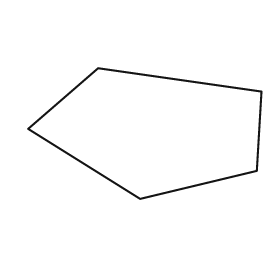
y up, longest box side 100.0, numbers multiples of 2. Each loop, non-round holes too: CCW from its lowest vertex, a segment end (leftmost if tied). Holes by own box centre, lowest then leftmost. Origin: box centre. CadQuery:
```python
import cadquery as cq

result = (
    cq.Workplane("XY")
    .moveTo(-2.0, -28.0)
    .lineTo(48.0, -16.0)
    .lineTo(50.0, 18.0)
    .lineTo(-20.0, 28.0)
    .lineTo(-50.0, 2.0)
    .close()
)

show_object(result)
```